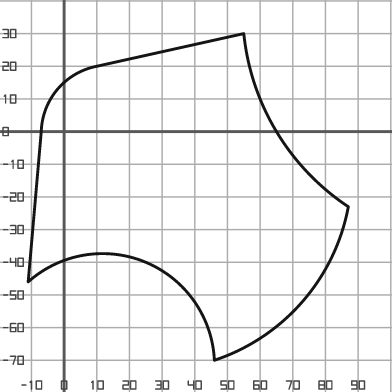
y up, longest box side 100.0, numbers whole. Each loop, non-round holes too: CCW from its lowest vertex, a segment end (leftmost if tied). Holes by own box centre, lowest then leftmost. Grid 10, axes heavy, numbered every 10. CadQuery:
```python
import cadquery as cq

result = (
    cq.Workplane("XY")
    .moveTo(46.0, -70.0)
    .threePointArc((73.0, -52.0), (87.0, -23.0))
    .threePointArc((65.0, 0.0), (55.0, 30.0))
    .lineTo(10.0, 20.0)
    .threePointArc((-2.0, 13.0), (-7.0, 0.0))
    .lineTo(-11.0, -46.0)
    .threePointArc((25.0, -40.0), (46.0, -70.0))
    .close()
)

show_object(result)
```